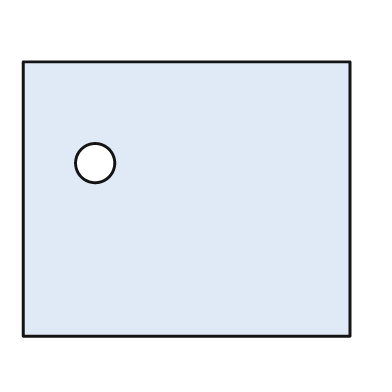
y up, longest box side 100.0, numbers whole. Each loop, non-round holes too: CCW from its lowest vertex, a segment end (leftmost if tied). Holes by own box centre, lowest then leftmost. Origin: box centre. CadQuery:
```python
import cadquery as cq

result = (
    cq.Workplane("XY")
    .moveTo(-50.0, -42.0)
    .lineTo(50.0, -42.0)
    .lineTo(50.0, 42.0)
    .lineTo(-50.0, 42.0)
    .close()
    .moveTo(-28.0, 11.0)
    .circle(6.0)
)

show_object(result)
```